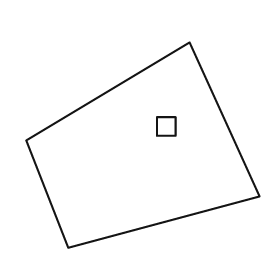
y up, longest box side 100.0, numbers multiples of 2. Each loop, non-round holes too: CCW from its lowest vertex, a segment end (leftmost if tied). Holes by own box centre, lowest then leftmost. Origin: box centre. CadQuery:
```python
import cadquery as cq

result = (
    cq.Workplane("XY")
    .moveTo(-32.0, -44.0)
    .lineTo(50.0, -22.0)
    .lineTo(20.0, 44.0)
    .lineTo(-50.0, 2.0)
    .close()
    .moveTo(6.0, 4.0)
    .lineTo(14.0, 4.0)
    .lineTo(14.0, 12.0)
    .lineTo(6.0, 12.0)
    .close()
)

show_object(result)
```